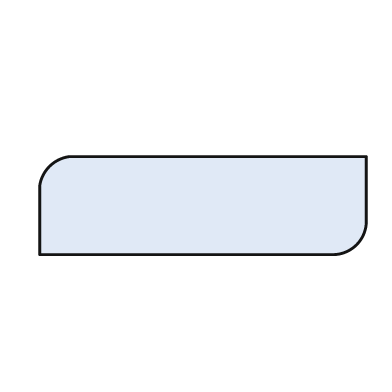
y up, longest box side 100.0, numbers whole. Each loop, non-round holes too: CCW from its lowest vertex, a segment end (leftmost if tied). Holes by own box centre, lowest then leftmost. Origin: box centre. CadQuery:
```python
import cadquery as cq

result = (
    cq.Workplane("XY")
    .moveTo(-50.0, -15.0)
    .lineTo(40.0, -15.0)
    .threePointArc((47.0, -12.0), (50.0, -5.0))
    .lineTo(50.0, 15.0)
    .lineTo(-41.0, 15.0)
    .threePointArc((-47.0, 12.0), (-50.0, 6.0))
    .close()
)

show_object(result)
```